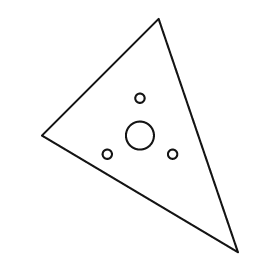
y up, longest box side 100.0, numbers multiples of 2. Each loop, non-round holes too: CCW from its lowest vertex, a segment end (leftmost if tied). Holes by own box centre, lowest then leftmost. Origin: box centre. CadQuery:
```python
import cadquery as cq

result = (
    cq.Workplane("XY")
    .moveTo(42.0, -50.0)
    .lineTo(8.0, 50.0)
    .lineTo(-42.0, 0.0)
    .close()
    .moveTo(-14.0, -8.0)
    .circle(2.0)
    .moveTo(14.0, -8.0)
    .circle(2.0)
    .moveTo(0.0, 0.0)
    .circle(6.0)
    .moveTo(0.0, 16.0)
    .circle(2.0)
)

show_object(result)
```